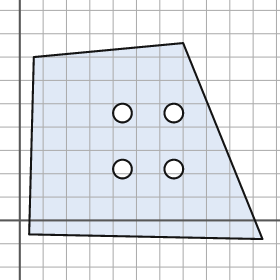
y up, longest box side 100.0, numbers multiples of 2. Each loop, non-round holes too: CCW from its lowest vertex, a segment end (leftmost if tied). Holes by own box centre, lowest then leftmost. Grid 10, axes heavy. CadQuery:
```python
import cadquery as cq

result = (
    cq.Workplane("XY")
    .moveTo(104.0, -8.0)
    .lineTo(70.0, 76.0)
    .lineTo(6.0, 70.0)
    .lineTo(4.0, -6.0)
    .close()
    .moveTo(44.0, 22.0)
    .circle(4.0)
    .moveTo(66.0, 22.0)
    .circle(4.0)
    .moveTo(44.0, 46.0)
    .circle(4.0)
    .moveTo(66.0, 46.0)
    .circle(4.0)
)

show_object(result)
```